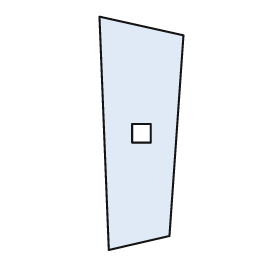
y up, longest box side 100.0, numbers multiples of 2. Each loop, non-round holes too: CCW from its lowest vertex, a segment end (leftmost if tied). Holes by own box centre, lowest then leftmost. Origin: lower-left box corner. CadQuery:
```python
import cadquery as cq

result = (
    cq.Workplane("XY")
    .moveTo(4.0, 0.0)
    .lineTo(30.0, 6.0)
    .lineTo(36.0, 92.0)
    .lineTo(0.0, 100.0)
    .close()
    .moveTo(14.0, 46.0)
    .lineTo(22.0, 46.0)
    .lineTo(22.0, 54.0)
    .lineTo(14.0, 54.0)
    .close()
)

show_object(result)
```